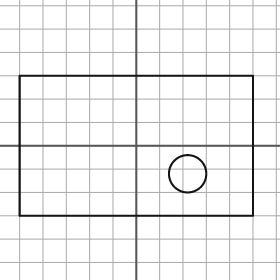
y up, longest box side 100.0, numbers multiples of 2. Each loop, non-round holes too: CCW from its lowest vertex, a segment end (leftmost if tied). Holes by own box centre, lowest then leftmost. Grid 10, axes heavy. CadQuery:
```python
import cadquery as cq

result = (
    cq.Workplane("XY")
    .moveTo(-50.0, -30.0)
    .lineTo(50.0, -30.0)
    .lineTo(50.0, 30.0)
    .lineTo(-50.0, 30.0)
    .close()
    .moveTo(22.0, -12.0)
    .circle(8.0)
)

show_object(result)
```